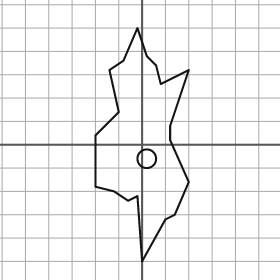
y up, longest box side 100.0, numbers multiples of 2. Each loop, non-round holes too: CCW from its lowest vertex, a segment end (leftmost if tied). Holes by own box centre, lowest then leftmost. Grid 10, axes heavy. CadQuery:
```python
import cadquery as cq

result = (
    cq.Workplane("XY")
    .moveTo(0.0, -50.0)
    .lineTo(10.0, -32.0)
    .lineTo(14.0, -30.0)
    .lineTo(20.0, -16.0)
    .lineTo(12.0, 2.0)
    .lineTo(12.0, 8.0)
    .lineTo(20.0, 32.0)
    .lineTo(8.0, 26.0)
    .lineTo(6.0, 34.0)
    .lineTo(2.0, 38.0)
    .lineTo(-2.0, 50.0)
    .lineTo(-8.0, 36.0)
    .lineTo(-14.0, 32.0)
    .lineTo(-10.0, 14.0)
    .lineTo(-20.0, 4.0)
    .lineTo(-20.0, -18.0)
    .lineTo(-12.0, -20.0)
    .lineTo(-6.0, -24.0)
    .lineTo(-2.0, -22.0)
    .close()
    .moveTo(2.0, -6.0)
    .circle(4.0)
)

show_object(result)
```